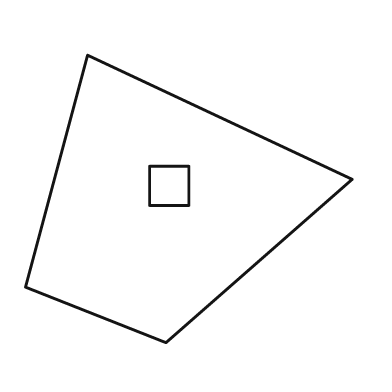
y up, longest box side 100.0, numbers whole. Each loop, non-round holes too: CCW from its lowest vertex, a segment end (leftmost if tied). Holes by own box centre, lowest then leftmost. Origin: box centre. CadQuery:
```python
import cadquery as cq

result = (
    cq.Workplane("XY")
    .moveTo(-7.0, -44.0)
    .lineTo(50.0, 6.0)
    .lineTo(-31.0, 44.0)
    .lineTo(-50.0, -27.0)
    .close()
    .moveTo(-12.0, -2.0)
    .lineTo(0.0, -2.0)
    .lineTo(0.0, 10.0)
    .lineTo(-12.0, 10.0)
    .close()
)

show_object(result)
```